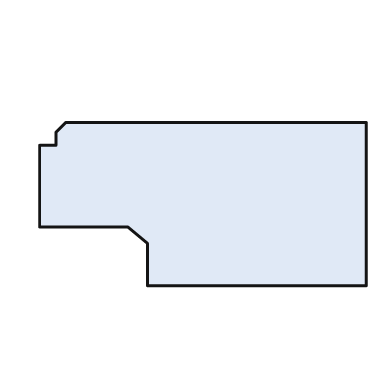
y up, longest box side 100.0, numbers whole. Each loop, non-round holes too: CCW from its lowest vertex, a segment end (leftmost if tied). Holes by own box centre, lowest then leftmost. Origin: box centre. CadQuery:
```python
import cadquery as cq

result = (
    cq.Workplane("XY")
    .moveTo(-17.0, -25.0)
    .lineTo(50.0, -25.0)
    .lineTo(50.0, 25.0)
    .lineTo(-42.0, 25.0)
    .lineTo(-45.0, 22.0)
    .lineTo(-45.0, 18.0)
    .lineTo(-50.0, 18.0)
    .lineTo(-50.0, -7.0)
    .lineTo(-23.0, -7.0)
    .lineTo(-17.0, -12.0)
    .close()
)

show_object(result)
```